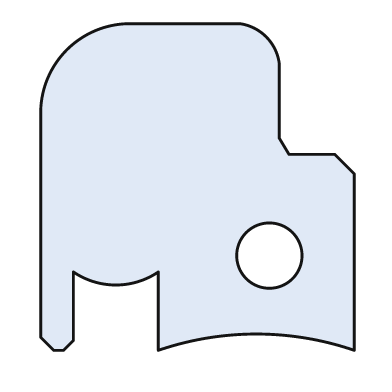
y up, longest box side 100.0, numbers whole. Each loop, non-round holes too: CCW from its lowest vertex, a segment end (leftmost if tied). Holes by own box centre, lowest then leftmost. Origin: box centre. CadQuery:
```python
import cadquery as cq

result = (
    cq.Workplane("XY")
    .moveTo(-44.0, -50.0)
    .lineTo(-41.0, -50.0)
    .lineTo(-38.0, -47.0)
    .lineTo(-38.0, -26.0)
    .threePointArc((-25.0, -30.0), (-12.0, -26.0))
    .lineTo(-12.0, -50.0)
    .threePointArc((18.0, -45.0), (48.0, -50.0))
    .lineTo(48.0, 4.0)
    .lineTo(42.0, 10.0)
    .lineTo(28.0, 10.0)
    .lineTo(25.0, 15.0)
    .lineTo(25.0, 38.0)
    .threePointArc((21.0, 46.0), (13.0, 50.0))
    .lineTo(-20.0, 50.0)
    .threePointArc((-40.0, 42.0), (-48.0, 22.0))
    .lineTo(-48.0, -46.0)
    .close()
    .moveTo(22.0, -21.0)
    .circle(10.0)
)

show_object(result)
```